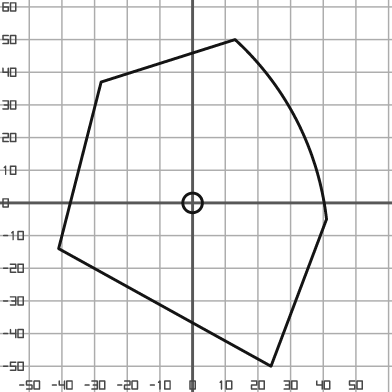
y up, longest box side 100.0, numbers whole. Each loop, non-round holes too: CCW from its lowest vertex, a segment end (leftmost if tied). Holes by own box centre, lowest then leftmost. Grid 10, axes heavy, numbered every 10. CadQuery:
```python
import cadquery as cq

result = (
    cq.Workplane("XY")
    .moveTo(24.0, -50.0)
    .lineTo(41.0, -5.0)
    .threePointArc((32.0, 25.0), (13.0, 50.0))
    .lineTo(-28.0, 37.0)
    .lineTo(-41.0, -14.0)
    .close()
    .moveTo(0.0, 0.0)
    .circle(3.0)
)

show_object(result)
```